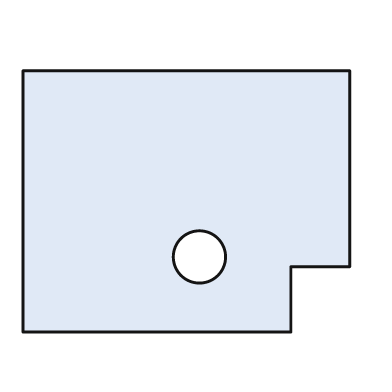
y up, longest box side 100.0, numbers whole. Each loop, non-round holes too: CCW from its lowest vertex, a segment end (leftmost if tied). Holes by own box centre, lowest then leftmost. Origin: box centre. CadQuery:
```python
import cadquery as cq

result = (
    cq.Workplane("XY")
    .moveTo(-50.0, -40.0)
    .lineTo(32.0, -40.0)
    .lineTo(32.0, -20.0)
    .lineTo(50.0, -20.0)
    .lineTo(50.0, 40.0)
    .lineTo(-50.0, 40.0)
    .close()
    .moveTo(4.0, -17.0)
    .circle(8.0)
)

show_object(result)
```